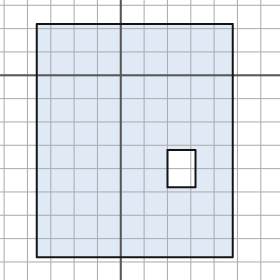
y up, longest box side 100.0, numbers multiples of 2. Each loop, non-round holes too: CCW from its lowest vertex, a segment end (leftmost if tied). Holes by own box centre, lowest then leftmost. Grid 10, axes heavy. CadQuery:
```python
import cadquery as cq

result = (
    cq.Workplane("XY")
    .moveTo(-36.0, -78.0)
    .lineTo(48.0, -78.0)
    .lineTo(48.0, 22.0)
    .lineTo(-36.0, 22.0)
    .close()
    .moveTo(20.0, -48.0)
    .lineTo(32.0, -48.0)
    .lineTo(32.0, -32.0)
    .lineTo(20.0, -32.0)
    .close()
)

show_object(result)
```